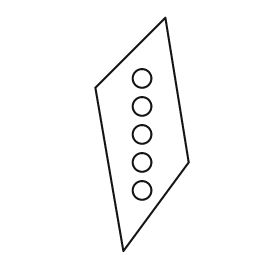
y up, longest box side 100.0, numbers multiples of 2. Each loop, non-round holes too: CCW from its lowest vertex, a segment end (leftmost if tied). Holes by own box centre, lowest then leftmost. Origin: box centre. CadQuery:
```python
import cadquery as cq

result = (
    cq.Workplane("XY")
    .moveTo(-8.0, -50.0)
    .lineTo(20.0, -12.0)
    .lineTo(10.0, 50.0)
    .lineTo(-20.0, 20.0)
    .close()
    .moveTo(0.0, -24.0)
    .circle(4.0)
    .moveTo(0.0, -12.0)
    .circle(4.0)
    .moveTo(0.0, 0.0)
    .circle(4.0)
    .moveTo(0.0, 12.0)
    .circle(4.0)
    .moveTo(0.0, 24.0)
    .circle(4.0)
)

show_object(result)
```